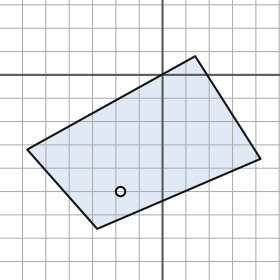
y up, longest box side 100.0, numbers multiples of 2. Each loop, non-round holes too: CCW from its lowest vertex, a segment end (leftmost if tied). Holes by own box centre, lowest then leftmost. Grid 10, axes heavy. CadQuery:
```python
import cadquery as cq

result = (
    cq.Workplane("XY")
    .moveTo(-28.0, -66.0)
    .lineTo(42.0, -36.0)
    .lineTo(14.0, 8.0)
    .lineTo(-58.0, -32.0)
    .close()
    .moveTo(-18.0, -50.0)
    .circle(2.0)
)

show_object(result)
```